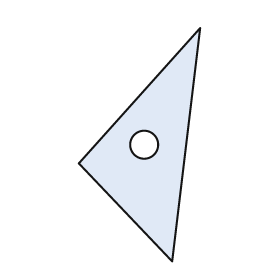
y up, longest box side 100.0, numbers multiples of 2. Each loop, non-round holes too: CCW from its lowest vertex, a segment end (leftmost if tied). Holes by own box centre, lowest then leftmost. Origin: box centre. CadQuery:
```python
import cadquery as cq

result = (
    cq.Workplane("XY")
    .moveTo(14.0, -50.0)
    .lineTo(26.0, 50.0)
    .lineTo(-26.0, -8.0)
    .close()
    .moveTo(2.0, 0.0)
    .circle(6.0)
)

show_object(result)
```